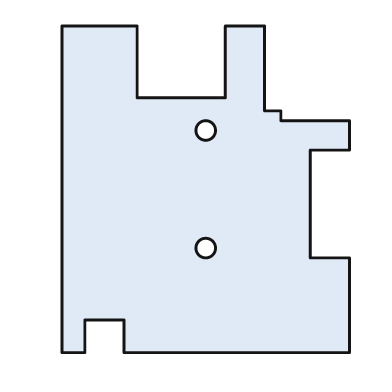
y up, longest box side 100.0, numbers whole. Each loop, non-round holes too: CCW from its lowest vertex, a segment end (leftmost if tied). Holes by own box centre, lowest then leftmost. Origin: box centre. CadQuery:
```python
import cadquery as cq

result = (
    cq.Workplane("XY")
    .moveTo(-44.0, -50.0)
    .lineTo(-37.0, -50.0)
    .lineTo(-37.0, -40.0)
    .lineTo(-25.0, -40.0)
    .lineTo(-25.0, -50.0)
    .lineTo(44.0, -50.0)
    .lineTo(44.0, -21.0)
    .lineTo(32.0, -21.0)
    .lineTo(32.0, 12.0)
    .lineTo(44.0, 12.0)
    .lineTo(44.0, 21.0)
    .lineTo(23.0, 21.0)
    .lineTo(23.0, 24.0)
    .lineTo(18.0, 24.0)
    .lineTo(18.0, 50.0)
    .lineTo(6.0, 50.0)
    .lineTo(6.0, 28.0)
    .lineTo(-21.0, 28.0)
    .lineTo(-21.0, 50.0)
    .lineTo(-44.0, 50.0)
    .close()
    .moveTo(0.0, -18.0)
    .circle(3.0)
    .moveTo(0.0, 18.0)
    .circle(3.0)
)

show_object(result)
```